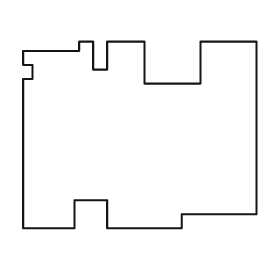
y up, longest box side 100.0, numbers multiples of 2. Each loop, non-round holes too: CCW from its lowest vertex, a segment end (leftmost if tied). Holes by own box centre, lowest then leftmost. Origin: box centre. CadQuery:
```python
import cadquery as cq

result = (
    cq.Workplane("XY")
    .moveTo(-50.0, -40.0)
    .lineTo(-28.0, -40.0)
    .lineTo(-28.0, -28.0)
    .lineTo(-14.0, -28.0)
    .lineTo(-14.0, -40.0)
    .lineTo(18.0, -40.0)
    .lineTo(18.0, -34.0)
    .lineTo(50.0, -34.0)
    .lineTo(50.0, 40.0)
    .lineTo(26.0, 40.0)
    .lineTo(26.0, 22.0)
    .lineTo(2.0, 22.0)
    .lineTo(2.0, 40.0)
    .lineTo(-14.0, 40.0)
    .lineTo(-14.0, 28.0)
    .lineTo(-20.0, 28.0)
    .lineTo(-20.0, 40.0)
    .lineTo(-26.0, 40.0)
    .lineTo(-26.0, 36.0)
    .lineTo(-50.0, 36.0)
    .lineTo(-50.0, 30.0)
    .lineTo(-46.0, 30.0)
    .lineTo(-46.0, 24.0)
    .lineTo(-50.0, 24.0)
    .close()
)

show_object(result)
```